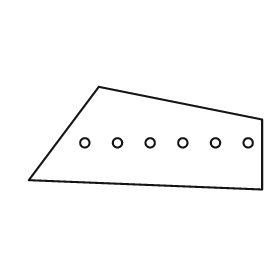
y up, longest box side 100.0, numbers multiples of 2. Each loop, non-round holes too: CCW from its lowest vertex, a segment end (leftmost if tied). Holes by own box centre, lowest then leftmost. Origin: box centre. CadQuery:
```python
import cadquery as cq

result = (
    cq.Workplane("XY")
    .moveTo(50.0, -22.0)
    .lineTo(50.0, 8.0)
    .lineTo(-20.0, 22.0)
    .lineTo(-50.0, -18.0)
    .close()
    .moveTo(-26.0, -2.0)
    .circle(2.0)
    .moveTo(-12.0, -2.0)
    .circle(2.0)
    .moveTo(2.0, -2.0)
    .circle(2.0)
    .moveTo(16.0, -2.0)
    .circle(2.0)
    .moveTo(30.0, -2.0)
    .circle(2.0)
    .moveTo(44.0, -2.0)
    .circle(2.0)
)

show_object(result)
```